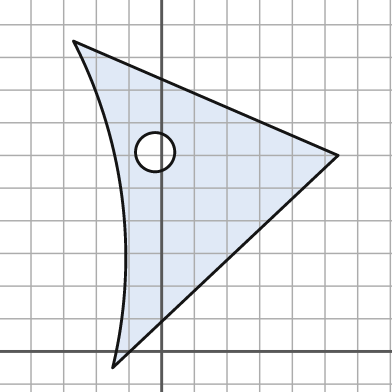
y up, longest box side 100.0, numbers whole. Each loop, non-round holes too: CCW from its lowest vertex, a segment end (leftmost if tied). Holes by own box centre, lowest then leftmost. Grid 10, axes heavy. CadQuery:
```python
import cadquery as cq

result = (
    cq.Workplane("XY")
    .moveTo(-15.0, -5.0)
    .lineTo(54.0, 60.0)
    .lineTo(-27.0, 95.0)
    .threePointArc((-12.0, 46.0), (-15.0, -5.0))
    .close()
    .moveTo(-2.0, 61.0)
    .circle(6.0)
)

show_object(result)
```